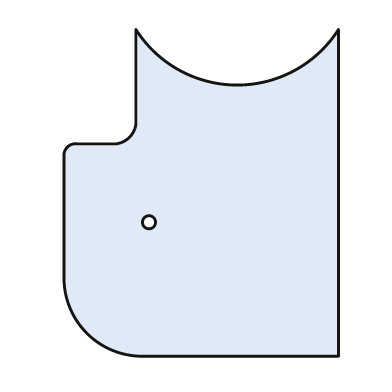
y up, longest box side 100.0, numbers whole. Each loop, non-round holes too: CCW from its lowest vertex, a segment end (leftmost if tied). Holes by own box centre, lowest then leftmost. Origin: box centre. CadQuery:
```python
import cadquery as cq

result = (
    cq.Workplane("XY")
    .moveTo(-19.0, -50.0)
    .lineTo(42.0, -50.0)
    .lineTo(42.0, 50.0)
    .threePointArc((11.0, 33.0), (-20.0, 50.0))
    .lineTo(-20.0, 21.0)
    .threePointArc((-22.0, 17.0), (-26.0, 15.0))
    .lineTo(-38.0, 15.0)
    .threePointArc((-41.0, 14.0), (-42.0, 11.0))
    .lineTo(-42.0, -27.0)
    .threePointArc((-35.0, -43.0), (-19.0, -50.0))
    .close()
    .moveTo(-16.0, -9.0)
    .circle(2.0)
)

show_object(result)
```